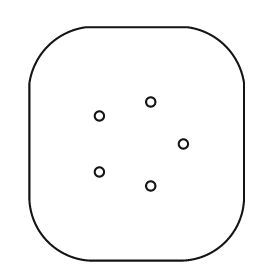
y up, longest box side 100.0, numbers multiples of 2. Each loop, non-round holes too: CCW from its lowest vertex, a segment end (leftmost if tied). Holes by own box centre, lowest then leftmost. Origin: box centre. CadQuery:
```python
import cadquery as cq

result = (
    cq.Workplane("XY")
    .moveTo(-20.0, -50.0)
    .lineTo(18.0, -50.0)
    .threePointArc((38.0, -42.0), (46.0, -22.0))
    .lineTo(46.0, 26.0)
    .threePointArc((38.0, 42.0), (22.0, 50.0))
    .lineTo(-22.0, 50.0)
    .threePointArc((-38.0, 42.0), (-46.0, 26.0))
    .lineTo(-46.0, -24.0)
    .threePointArc((-38.0, -42.0), (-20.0, -50.0))
    .close()
    .moveTo(6.0, -18.0)
    .circle(2.0)
    .moveTo(-16.0, -12.0)
    .circle(2.0)
    .moveTo(20.0, 0.0)
    .circle(2.0)
    .moveTo(-16.0, 12.0)
    .circle(2.0)
    .moveTo(6.0, 18.0)
    .circle(2.0)
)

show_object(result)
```